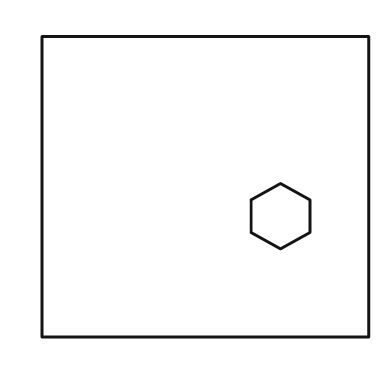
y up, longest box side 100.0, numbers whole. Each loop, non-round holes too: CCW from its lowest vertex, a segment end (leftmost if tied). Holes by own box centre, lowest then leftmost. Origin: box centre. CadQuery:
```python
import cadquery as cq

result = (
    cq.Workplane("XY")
    .moveTo(-50.0, -46.0)
    .lineTo(50.0, -46.0)
    .lineTo(50.0, 46.0)
    .lineTo(-50.0, 46.0)
    .close()
    .moveTo(23.0, -19.0)
    .lineTo(32.0, -14.0)
    .lineTo(32.0, -4.0)
    .lineTo(23.0, 1.0)
    .lineTo(14.0, -4.0)
    .lineTo(14.0, -14.0)
    .close()
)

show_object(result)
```